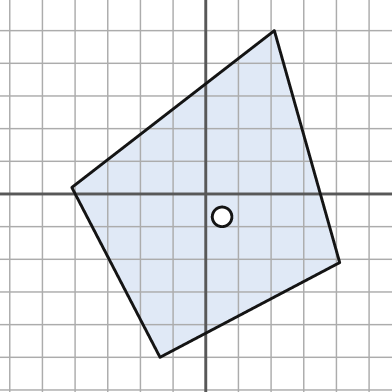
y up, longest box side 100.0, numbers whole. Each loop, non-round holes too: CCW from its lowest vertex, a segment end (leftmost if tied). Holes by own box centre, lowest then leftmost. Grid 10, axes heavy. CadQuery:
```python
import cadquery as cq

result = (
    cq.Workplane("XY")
    .moveTo(-14.0, -50.0)
    .lineTo(41.0, -21.0)
    .lineTo(21.0, 50.0)
    .lineTo(-41.0, 2.0)
    .close()
    .moveTo(5.0, -7.0)
    .circle(3.0)
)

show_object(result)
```